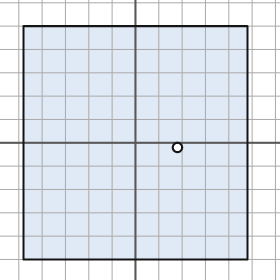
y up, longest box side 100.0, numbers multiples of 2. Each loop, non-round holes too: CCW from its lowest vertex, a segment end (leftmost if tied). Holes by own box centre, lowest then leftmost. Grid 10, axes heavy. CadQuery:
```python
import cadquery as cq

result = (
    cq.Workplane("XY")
    .moveTo(-48.0, -50.0)
    .lineTo(48.0, -50.0)
    .lineTo(48.0, 50.0)
    .lineTo(-48.0, 50.0)
    .close()
    .moveTo(18.0, -2.0)
    .circle(2.0)
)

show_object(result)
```